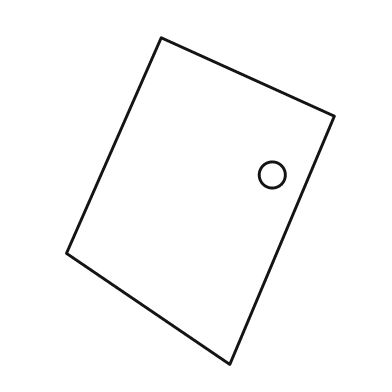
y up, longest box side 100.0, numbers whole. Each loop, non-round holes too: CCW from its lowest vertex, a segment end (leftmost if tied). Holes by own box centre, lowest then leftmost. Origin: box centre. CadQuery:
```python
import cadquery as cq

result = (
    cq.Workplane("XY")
    .moveTo(9.0, -50.0)
    .lineTo(41.0, 26.0)
    .lineTo(-12.0, 50.0)
    .lineTo(-41.0, -16.0)
    .close()
    .moveTo(22.0, 8.0)
    .circle(4.0)
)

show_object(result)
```